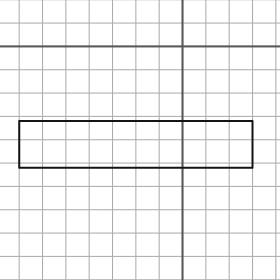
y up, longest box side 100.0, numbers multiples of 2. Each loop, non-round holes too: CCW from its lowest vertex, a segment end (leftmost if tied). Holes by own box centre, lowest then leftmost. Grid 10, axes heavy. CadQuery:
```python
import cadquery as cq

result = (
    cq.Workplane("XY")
    .moveTo(-70.0, -52.0)
    .lineTo(30.0, -52.0)
    .lineTo(30.0, -32.0)
    .lineTo(-70.0, -32.0)
    .close()
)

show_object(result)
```